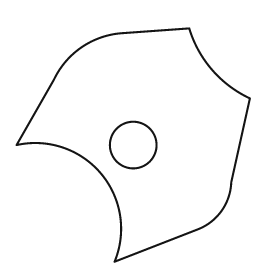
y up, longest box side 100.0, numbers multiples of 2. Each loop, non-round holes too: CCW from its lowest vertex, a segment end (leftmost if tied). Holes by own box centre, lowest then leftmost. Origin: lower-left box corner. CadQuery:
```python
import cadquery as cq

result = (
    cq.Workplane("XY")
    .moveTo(42.0, 0.0)
    .lineTo(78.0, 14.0)
    .threePointArc((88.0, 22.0), (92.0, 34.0))
    .lineTo(100.0, 70.0)
    .threePointArc((84.0, 82.0), (74.0, 100.0))
    .lineTo(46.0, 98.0)
    .threePointArc((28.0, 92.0), (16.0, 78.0))
    .lineTo(0.0, 50.0)
    .threePointArc((36.0, 38.0), (42.0, 0.0))
    .close()
    .moveTo(50.0, 50.0)
    .circle(10.0)
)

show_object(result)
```